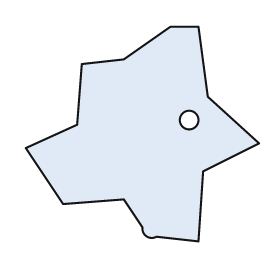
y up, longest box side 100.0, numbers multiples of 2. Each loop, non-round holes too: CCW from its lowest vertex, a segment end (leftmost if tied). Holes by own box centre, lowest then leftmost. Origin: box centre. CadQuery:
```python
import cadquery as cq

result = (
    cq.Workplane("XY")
    .moveTo(24.0, -46.0)
    .lineTo(26.0, -16.0)
    .lineTo(50.0, -4.0)
    .lineTo(28.0, 16.0)
    .lineTo(24.0, 46.0)
    .lineTo(12.0, 46.0)
    .lineTo(-8.0, 32.0)
    .lineTo(-26.0, 30.0)
    .lineTo(-28.0, 4.0)
    .lineTo(-50.0, -6.0)
    .lineTo(-34.0, -30.0)
    .lineTo(-8.0, -28.0)
    .lineTo(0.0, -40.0)
    .threePointArc((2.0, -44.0), (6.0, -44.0))
    .close()
    .moveTo(20.0, 6.0)
    .circle(4.0)
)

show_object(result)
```